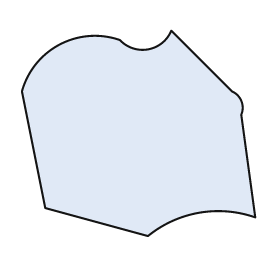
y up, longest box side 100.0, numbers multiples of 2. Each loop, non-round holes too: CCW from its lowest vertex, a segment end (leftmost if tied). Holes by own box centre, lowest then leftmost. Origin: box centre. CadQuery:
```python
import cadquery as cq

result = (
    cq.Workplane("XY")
    .moveTo(4.0, -44.0)
    .threePointArc((26.0, -34.0), (50.0, -36.0))
    .lineTo(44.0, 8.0)
    .threePointArc((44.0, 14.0), (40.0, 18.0))
    .lineTo(14.0, 44.0)
    .threePointArc((4.0, 36.0), (-8.0, 40.0))
    .threePointArc((-34.0, 38.0), (-50.0, 18.0))
    .lineTo(-40.0, -32.0)
    .close()
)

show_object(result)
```